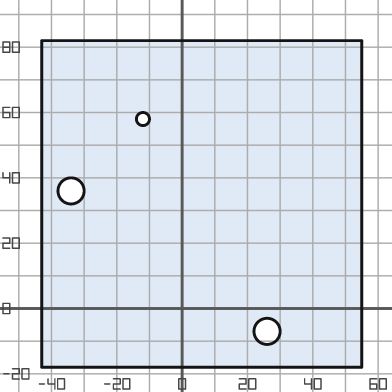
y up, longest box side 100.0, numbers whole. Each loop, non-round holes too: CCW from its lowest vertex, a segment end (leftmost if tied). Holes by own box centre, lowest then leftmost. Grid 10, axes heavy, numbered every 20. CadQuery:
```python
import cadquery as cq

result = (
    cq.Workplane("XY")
    .moveTo(-43.0, -18.0)
    .lineTo(55.0, -18.0)
    .lineTo(55.0, 82.0)
    .lineTo(-43.0, 82.0)
    .close()
    .moveTo(26.0, -7.0)
    .circle(4.0)
    .moveTo(-34.0, 36.0)
    .circle(4.0)
    .moveTo(-12.0, 58.0)
    .circle(2.0)
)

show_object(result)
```